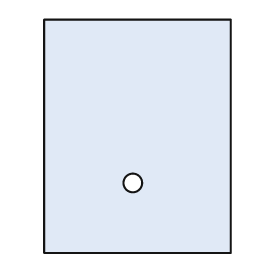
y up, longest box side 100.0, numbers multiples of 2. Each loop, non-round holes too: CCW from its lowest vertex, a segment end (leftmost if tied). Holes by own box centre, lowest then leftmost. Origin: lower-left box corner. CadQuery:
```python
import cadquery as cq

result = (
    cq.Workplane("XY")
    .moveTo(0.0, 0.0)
    .lineTo(80.0, 0.0)
    .lineTo(80.0, 100.0)
    .lineTo(0.0, 100.0)
    .close()
    .moveTo(38.0, 30.0)
    .circle(4.0)
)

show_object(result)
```